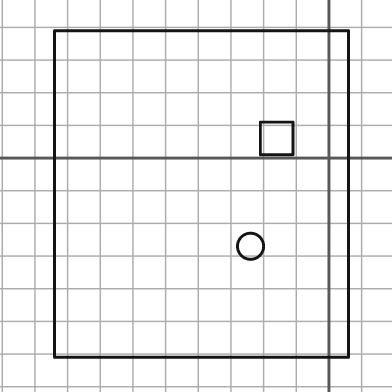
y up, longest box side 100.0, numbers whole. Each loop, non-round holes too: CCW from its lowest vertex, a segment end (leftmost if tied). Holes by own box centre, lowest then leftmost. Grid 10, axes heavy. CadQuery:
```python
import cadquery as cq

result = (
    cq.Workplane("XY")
    .moveTo(-84.0, -61.0)
    .lineTo(6.0, -61.0)
    .lineTo(6.0, 39.0)
    .lineTo(-84.0, 39.0)
    .close()
    .moveTo(-24.0, -27.0)
    .circle(4.0)
    .moveTo(-21.0, 1.0)
    .lineTo(-11.0, 1.0)
    .lineTo(-11.0, 11.0)
    .lineTo(-21.0, 11.0)
    .close()
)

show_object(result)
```